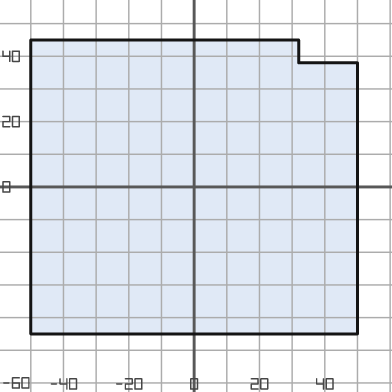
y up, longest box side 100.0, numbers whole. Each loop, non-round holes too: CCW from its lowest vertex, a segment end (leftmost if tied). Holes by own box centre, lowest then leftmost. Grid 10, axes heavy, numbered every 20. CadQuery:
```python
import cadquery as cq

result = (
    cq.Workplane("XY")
    .moveTo(-50.0, -45.0)
    .lineTo(50.0, -45.0)
    .lineTo(50.0, 38.0)
    .lineTo(32.0, 38.0)
    .lineTo(32.0, 45.0)
    .lineTo(-50.0, 45.0)
    .close()
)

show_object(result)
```